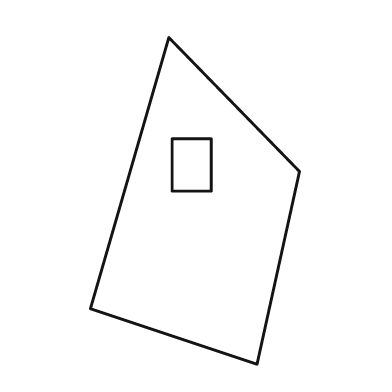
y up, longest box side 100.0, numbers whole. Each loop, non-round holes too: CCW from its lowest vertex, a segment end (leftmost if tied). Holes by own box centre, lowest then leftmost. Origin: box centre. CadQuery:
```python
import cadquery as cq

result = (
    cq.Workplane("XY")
    .moveTo(19.0, -50.0)
    .lineTo(32.0, 9.0)
    .lineTo(-8.0, 50.0)
    .lineTo(-32.0, -33.0)
    .close()
    .moveTo(-7.0, 3.0)
    .lineTo(5.0, 3.0)
    .lineTo(5.0, 19.0)
    .lineTo(-7.0, 19.0)
    .close()
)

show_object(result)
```